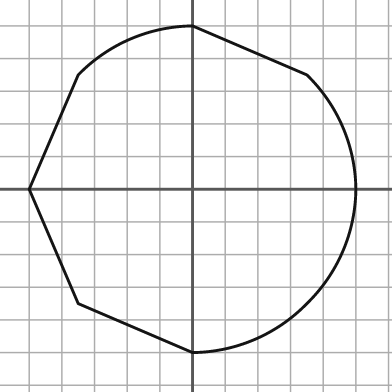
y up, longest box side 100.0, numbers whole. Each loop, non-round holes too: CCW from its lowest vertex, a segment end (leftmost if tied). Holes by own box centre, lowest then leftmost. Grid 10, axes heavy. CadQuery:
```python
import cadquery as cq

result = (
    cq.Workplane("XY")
    .moveTo(0.0, -50.0)
    .threePointArc((19.0, -46.0), (35.0, -35.0))
    .threePointArc((46.0, -19.0), (50.0, 0.0))
    .threePointArc((46.0, 19.0), (35.0, 35.0))
    .lineTo(0.0, 50.0)
    .threePointArc((-19.0, 46.0), (-35.0, 35.0))
    .lineTo(-50.0, 0.0)
    .lineTo(-35.0, -35.0)
    .close()
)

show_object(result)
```